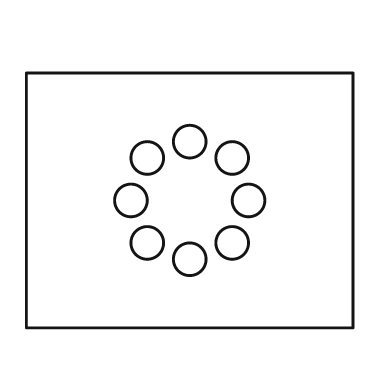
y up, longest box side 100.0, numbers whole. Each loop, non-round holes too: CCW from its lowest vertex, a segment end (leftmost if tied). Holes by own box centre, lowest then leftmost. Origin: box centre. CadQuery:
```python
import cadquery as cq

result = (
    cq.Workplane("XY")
    .moveTo(-50.0, -39.0)
    .lineTo(50.0, -39.0)
    .lineTo(50.0, 39.0)
    .lineTo(-50.0, 39.0)
    .close()
    .moveTo(0.0, -18.0)
    .circle(5.0)
    .moveTo(-13.0, -13.0)
    .circle(5.0)
    .moveTo(13.0, -13.0)
    .circle(5.0)
    .moveTo(-18.0, 0.0)
    .circle(5.0)
    .moveTo(18.0, 0.0)
    .circle(5.0)
    .moveTo(-13.0, 13.0)
    .circle(5.0)
    .moveTo(13.0, 13.0)
    .circle(5.0)
    .moveTo(0.0, 18.0)
    .circle(5.0)
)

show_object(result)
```